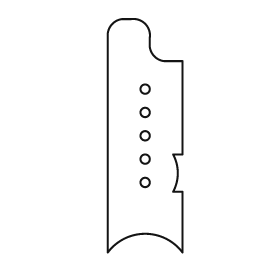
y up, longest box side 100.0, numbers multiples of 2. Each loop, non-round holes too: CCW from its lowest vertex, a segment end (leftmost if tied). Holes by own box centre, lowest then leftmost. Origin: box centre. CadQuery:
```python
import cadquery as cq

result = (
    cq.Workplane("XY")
    .moveTo(-16.0, -50.0)
    .threePointArc((0.0, -42.0), (16.0, -50.0))
    .lineTo(16.0, -24.0)
    .lineTo(12.0, -24.0)
    .threePointArc((14.0, -16.0), (12.0, -8.0))
    .lineTo(16.0, -8.0)
    .lineTo(16.0, 32.0)
    .lineTo(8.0, 32.0)
    .threePointArc((4.0, 34.0), (2.0, 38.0))
    .lineTo(2.0, 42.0)
    .threePointArc((0.0, 48.0), (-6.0, 50.0))
    .lineTo(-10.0, 50.0)
    .threePointArc((-14.0, 48.0), (-16.0, 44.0))
    .close()
    .moveTo(0.0, -20.0)
    .circle(2.0)
    .moveTo(0.0, -10.0)
    .circle(2.0)
    .moveTo(0.0, 0.0)
    .circle(2.0)
    .moveTo(0.0, 10.0)
    .circle(2.0)
    .moveTo(0.0, 20.0)
    .circle(2.0)
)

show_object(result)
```